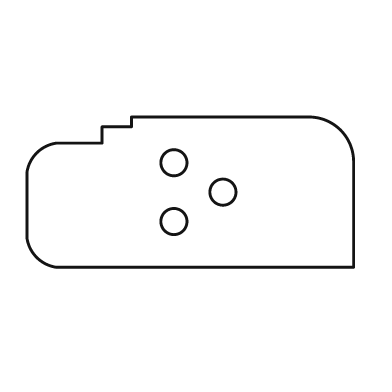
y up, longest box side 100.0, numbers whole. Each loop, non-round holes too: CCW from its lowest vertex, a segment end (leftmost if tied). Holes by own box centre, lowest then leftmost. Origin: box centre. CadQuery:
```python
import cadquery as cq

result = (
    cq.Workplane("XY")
    .moveTo(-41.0, -23.0)
    .lineTo(50.0, -23.0)
    .lineTo(50.0, 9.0)
    .threePointArc((46.0, 19.0), (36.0, 23.0))
    .lineTo(-18.0, 23.0)
    .lineTo(-18.0, 20.0)
    .lineTo(-27.0, 20.0)
    .lineTo(-27.0, 15.0)
    .lineTo(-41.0, 15.0)
    .threePointArc((-47.0, 12.0), (-50.0, 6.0))
    .lineTo(-50.0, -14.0)
    .threePointArc((-47.0, -20.0), (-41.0, -23.0))
    .close()
    .moveTo(-5.0, -9.0)
    .circle(4.0)
    .moveTo(10.0, 0.0)
    .circle(4.0)
    .moveTo(-5.0, 9.0)
    .circle(4.0)
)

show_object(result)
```